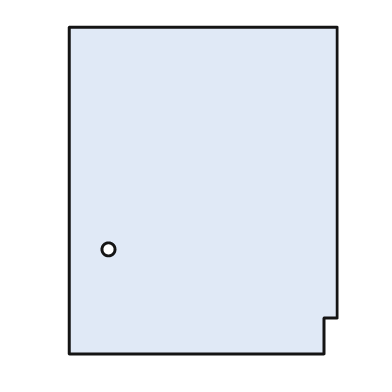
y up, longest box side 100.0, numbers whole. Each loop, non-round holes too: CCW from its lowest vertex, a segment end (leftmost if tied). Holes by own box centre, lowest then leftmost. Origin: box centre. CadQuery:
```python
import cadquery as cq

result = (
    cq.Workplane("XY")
    .moveTo(-41.0, -50.0)
    .lineTo(37.0, -50.0)
    .lineTo(37.0, -39.0)
    .lineTo(41.0, -39.0)
    .lineTo(41.0, 50.0)
    .lineTo(-41.0, 50.0)
    .close()
    .moveTo(-29.0, -18.0)
    .circle(2.0)
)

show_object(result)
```